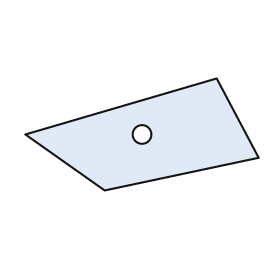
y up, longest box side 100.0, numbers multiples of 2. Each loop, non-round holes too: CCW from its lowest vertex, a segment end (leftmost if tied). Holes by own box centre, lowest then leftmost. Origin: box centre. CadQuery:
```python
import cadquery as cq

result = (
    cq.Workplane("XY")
    .moveTo(-16.0, -24.0)
    .lineTo(50.0, -10.0)
    .lineTo(32.0, 24.0)
    .lineTo(-50.0, 0.0)
    .close()
    .moveTo(0.0, 0.0)
    .circle(4.0)
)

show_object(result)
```